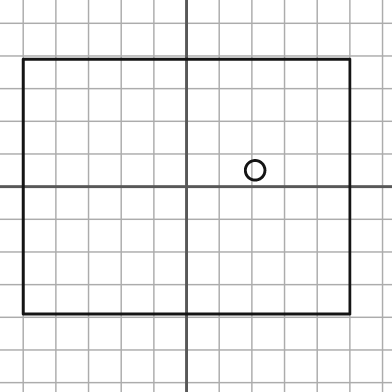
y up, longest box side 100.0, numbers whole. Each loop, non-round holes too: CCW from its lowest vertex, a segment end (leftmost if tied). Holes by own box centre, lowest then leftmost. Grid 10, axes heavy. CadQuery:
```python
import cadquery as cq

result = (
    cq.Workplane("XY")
    .moveTo(-50.0, -39.0)
    .lineTo(50.0, -39.0)
    .lineTo(50.0, 39.0)
    .lineTo(-50.0, 39.0)
    .close()
    .moveTo(21.0, 5.0)
    .circle(3.0)
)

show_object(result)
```